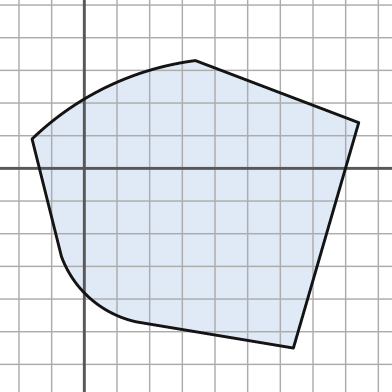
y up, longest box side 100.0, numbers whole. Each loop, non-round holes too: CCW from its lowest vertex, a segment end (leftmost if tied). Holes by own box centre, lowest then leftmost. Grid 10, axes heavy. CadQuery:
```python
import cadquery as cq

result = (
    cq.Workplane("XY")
    .moveTo(64.0, -55.0)
    .lineTo(84.0, 14.0)
    .lineTo(34.0, 33.0)
    .threePointArc((7.0, 25.0), (-16.0, 9.0))
    .lineTo(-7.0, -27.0)
    .threePointArc((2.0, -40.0), (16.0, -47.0))
    .close()
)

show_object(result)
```